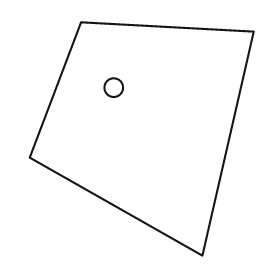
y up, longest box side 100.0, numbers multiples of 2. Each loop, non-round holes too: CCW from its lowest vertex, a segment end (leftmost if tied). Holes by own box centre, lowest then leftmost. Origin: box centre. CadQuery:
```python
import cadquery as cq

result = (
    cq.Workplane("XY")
    .moveTo(26.0, -50.0)
    .lineTo(48.0, 46.0)
    .lineTo(-26.0, 50.0)
    .lineTo(-48.0, -8.0)
    .close()
    .moveTo(-12.0, 22.0)
    .circle(4.0)
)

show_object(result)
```